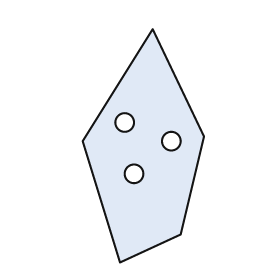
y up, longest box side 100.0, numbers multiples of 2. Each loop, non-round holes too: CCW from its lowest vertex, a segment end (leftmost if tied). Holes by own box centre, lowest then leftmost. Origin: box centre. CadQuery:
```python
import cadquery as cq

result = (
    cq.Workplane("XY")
    .moveTo(-10.0, -50.0)
    .lineTo(16.0, -38.0)
    .lineTo(26.0, 4.0)
    .lineTo(4.0, 50.0)
    .lineTo(-26.0, 2.0)
    .close()
    .moveTo(-4.0, -12.0)
    .circle(4.0)
    .moveTo(12.0, 2.0)
    .circle(4.0)
    .moveTo(-8.0, 10.0)
    .circle(4.0)
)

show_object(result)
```